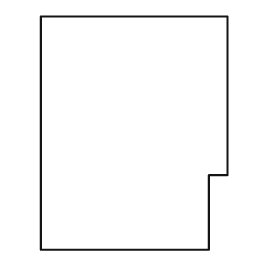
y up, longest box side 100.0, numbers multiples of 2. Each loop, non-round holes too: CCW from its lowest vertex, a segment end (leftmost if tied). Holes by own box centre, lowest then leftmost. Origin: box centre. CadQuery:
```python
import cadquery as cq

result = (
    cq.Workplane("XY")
    .moveTo(-40.0, -50.0)
    .lineTo(32.0, -50.0)
    .lineTo(32.0, -18.0)
    .lineTo(40.0, -18.0)
    .lineTo(40.0, 50.0)
    .lineTo(-40.0, 50.0)
    .close()
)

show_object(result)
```